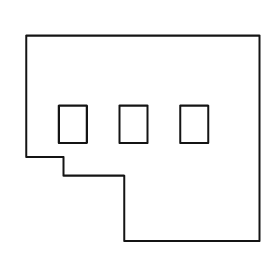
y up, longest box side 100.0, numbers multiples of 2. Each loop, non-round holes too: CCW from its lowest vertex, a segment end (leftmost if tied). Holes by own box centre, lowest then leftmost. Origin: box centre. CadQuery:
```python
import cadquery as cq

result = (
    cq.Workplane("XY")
    .moveTo(-8.0, -44.0)
    .lineTo(50.0, -44.0)
    .lineTo(50.0, 44.0)
    .lineTo(-50.0, 44.0)
    .lineTo(-50.0, -8.0)
    .lineTo(-34.0, -8.0)
    .lineTo(-34.0, -16.0)
    .lineTo(-8.0, -16.0)
    .close()
    .moveTo(-36.0, -2.0)
    .lineTo(-24.0, -2.0)
    .lineTo(-24.0, 14.0)
    .lineTo(-36.0, 14.0)
    .close()
    .moveTo(-10.0, -2.0)
    .lineTo(2.0, -2.0)
    .lineTo(2.0, 14.0)
    .lineTo(-10.0, 14.0)
    .close()
    .moveTo(16.0, -2.0)
    .lineTo(28.0, -2.0)
    .lineTo(28.0, 14.0)
    .lineTo(16.0, 14.0)
    .close()
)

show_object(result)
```